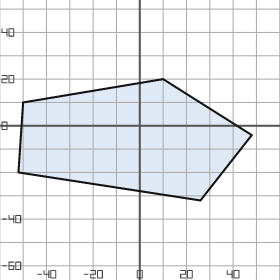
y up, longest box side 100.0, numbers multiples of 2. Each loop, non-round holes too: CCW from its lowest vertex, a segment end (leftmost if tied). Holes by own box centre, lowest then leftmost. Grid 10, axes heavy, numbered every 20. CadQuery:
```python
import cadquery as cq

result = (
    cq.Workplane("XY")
    .moveTo(26.0, -32.0)
    .lineTo(48.0, -4.0)
    .lineTo(10.0, 20.0)
    .lineTo(-50.0, 10.0)
    .lineTo(-52.0, -20.0)
    .close()
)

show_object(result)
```